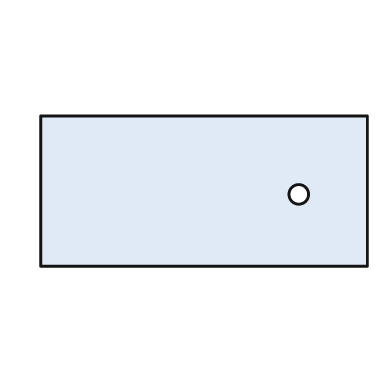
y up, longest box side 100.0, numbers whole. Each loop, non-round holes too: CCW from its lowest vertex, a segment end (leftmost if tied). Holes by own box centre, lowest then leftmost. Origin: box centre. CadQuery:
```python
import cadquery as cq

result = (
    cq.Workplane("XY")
    .moveTo(-50.0, -23.0)
    .lineTo(50.0, -23.0)
    .lineTo(50.0, 23.0)
    .lineTo(-50.0, 23.0)
    .close()
    .moveTo(29.0, -1.0)
    .circle(3.0)
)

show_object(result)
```